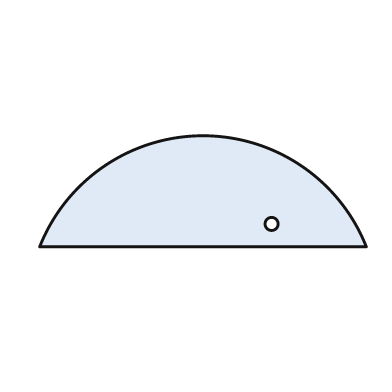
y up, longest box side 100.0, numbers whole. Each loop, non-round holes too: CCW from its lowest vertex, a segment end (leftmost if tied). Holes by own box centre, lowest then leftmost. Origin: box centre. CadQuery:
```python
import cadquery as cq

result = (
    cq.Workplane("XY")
    .moveTo(-50.0, -17.0)
    .lineTo(50.0, -17.0)
    .threePointArc((0.0, 17.0), (-50.0, -17.0))
    .close()
    .moveTo(21.0, -10.0)
    .circle(2.0)
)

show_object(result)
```